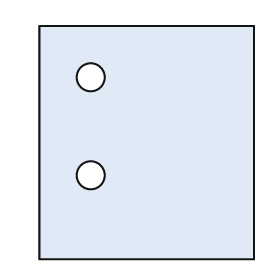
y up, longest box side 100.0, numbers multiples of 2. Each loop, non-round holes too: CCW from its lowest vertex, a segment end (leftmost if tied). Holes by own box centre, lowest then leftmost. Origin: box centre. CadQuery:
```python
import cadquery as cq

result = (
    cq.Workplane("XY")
    .moveTo(-46.0, -50.0)
    .lineTo(46.0, -50.0)
    .lineTo(46.0, 50.0)
    .lineTo(-46.0, 50.0)
    .close()
    .moveTo(-24.0, -14.0)
    .circle(6.0)
    .moveTo(-24.0, 28.0)
    .circle(6.0)
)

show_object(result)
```